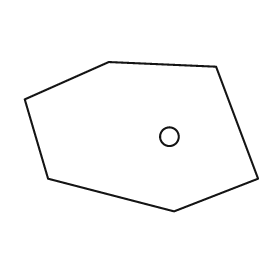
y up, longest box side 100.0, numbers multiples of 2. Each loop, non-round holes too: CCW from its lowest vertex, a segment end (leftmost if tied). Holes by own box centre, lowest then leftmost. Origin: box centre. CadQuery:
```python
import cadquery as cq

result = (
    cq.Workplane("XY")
    .moveTo(14.0, -32.0)
    .lineTo(50.0, -18.0)
    .lineTo(32.0, 30.0)
    .lineTo(-14.0, 32.0)
    .lineTo(-50.0, 16.0)
    .lineTo(-40.0, -18.0)
    .close()
    .moveTo(12.0, 0.0)
    .circle(4.0)
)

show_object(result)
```